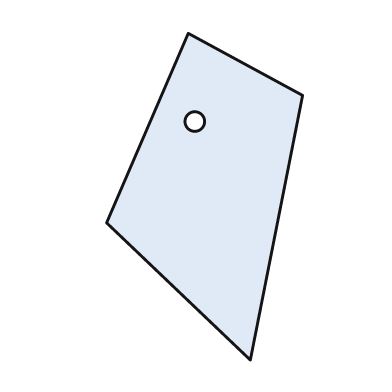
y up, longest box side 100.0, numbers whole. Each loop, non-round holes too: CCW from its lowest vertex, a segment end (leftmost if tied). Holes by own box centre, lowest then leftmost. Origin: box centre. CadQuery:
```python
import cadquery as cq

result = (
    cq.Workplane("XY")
    .moveTo(14.0, -50.0)
    .lineTo(30.0, 31.0)
    .lineTo(-5.0, 50.0)
    .lineTo(-30.0, -8.0)
    .close()
    .moveTo(-3.0, 23.0)
    .circle(3.0)
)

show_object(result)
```